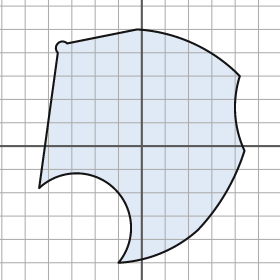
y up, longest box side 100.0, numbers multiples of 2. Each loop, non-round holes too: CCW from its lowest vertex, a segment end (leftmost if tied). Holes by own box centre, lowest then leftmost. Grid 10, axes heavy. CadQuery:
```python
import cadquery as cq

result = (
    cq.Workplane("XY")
    .moveTo(-10.0, -50.0)
    .threePointArc((8.0, -46.0), (24.0, -36.0))
    .threePointArc((36.0, -20.0), (44.0, -2.0))
    .threePointArc((40.0, 14.0), (42.0, 30.0))
    .threePointArc((22.0, 44.0), (-2.0, 50.0))
    .lineTo(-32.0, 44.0)
    .threePointArc((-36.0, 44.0), (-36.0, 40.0))
    .lineTo(-44.0, -18.0)
    .threePointArc((-12.0, -18.0), (-10.0, -50.0))
    .close()
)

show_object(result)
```